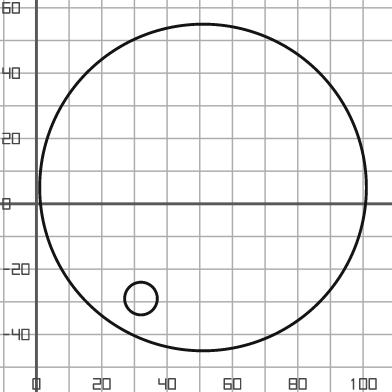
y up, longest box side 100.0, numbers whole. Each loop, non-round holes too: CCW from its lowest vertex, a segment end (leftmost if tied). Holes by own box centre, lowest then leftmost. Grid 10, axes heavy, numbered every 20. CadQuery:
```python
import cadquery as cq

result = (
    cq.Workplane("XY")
    .moveTo(51.0, 5.0)
    .circle(50.0)
    .moveTo(32.0, -29.0)
    .circle(5.0)
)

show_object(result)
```